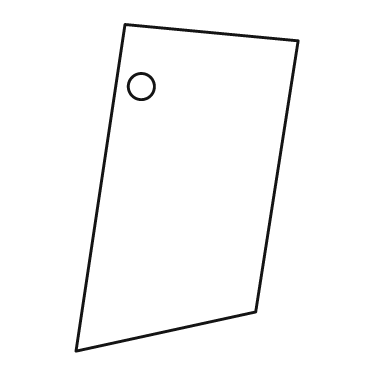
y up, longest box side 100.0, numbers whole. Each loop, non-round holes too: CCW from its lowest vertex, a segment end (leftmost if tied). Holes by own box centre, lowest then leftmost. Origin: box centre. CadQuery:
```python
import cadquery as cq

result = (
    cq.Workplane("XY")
    .moveTo(-34.0, -50.0)
    .lineTo(21.0, -38.0)
    .lineTo(34.0, 45.0)
    .lineTo(-19.0, 50.0)
    .close()
    .moveTo(-14.0, 31.0)
    .circle(4.0)
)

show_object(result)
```